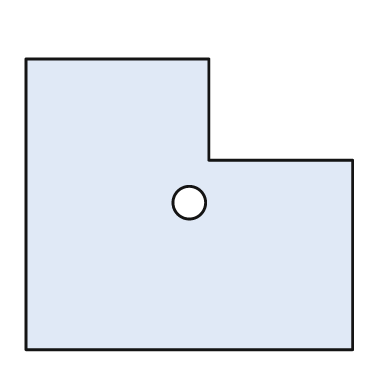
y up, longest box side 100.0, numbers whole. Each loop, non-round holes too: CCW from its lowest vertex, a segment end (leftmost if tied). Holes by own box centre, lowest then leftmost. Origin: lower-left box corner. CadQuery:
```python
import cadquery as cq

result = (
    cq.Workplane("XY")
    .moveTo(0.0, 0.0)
    .lineTo(100.0, 0.0)
    .lineTo(100.0, 58.0)
    .lineTo(56.0, 58.0)
    .lineTo(56.0, 89.0)
    .lineTo(0.0, 89.0)
    .close()
    .moveTo(50.0, 45.0)
    .circle(5.0)
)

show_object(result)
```